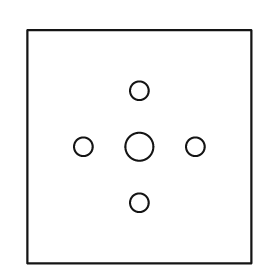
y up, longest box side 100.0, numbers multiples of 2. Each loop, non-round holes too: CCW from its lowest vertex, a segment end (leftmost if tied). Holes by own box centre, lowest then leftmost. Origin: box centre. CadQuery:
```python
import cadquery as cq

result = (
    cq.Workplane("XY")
    .moveTo(-48.0, -50.0)
    .lineTo(48.0, -50.0)
    .lineTo(48.0, 50.0)
    .lineTo(-48.0, 50.0)
    .close()
    .moveTo(0.0, -24.0)
    .circle(4.0)
    .moveTo(-24.0, 0.0)
    .circle(4.0)
    .moveTo(0.0, 0.0)
    .circle(6.0)
    .moveTo(24.0, 0.0)
    .circle(4.0)
    .moveTo(0.0, 24.0)
    .circle(4.0)
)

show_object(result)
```